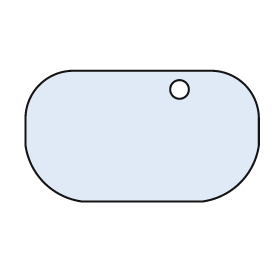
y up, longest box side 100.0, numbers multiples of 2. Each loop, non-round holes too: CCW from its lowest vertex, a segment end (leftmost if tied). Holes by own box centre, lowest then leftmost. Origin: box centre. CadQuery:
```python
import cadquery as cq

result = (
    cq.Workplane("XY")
    .moveTo(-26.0, -28.0)
    .lineTo(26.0, -28.0)
    .threePointArc((42.0, -20.0), (50.0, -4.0))
    .lineTo(50.0, 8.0)
    .threePointArc((44.0, 22.0), (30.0, 28.0))
    .lineTo(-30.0, 28.0)
    .threePointArc((-44.0, 22.0), (-50.0, 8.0))
    .lineTo(-50.0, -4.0)
    .threePointArc((-42.0, -20.0), (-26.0, -28.0))
    .close()
    .moveTo(16.0, 20.0)
    .circle(4.0)
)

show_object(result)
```